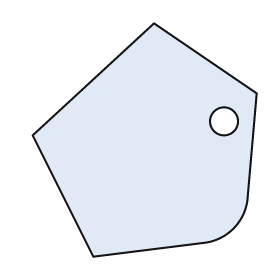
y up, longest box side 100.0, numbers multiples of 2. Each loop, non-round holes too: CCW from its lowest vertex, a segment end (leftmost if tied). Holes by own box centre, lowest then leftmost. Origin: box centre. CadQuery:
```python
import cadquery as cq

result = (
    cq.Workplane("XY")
    .moveTo(-22.0, -50.0)
    .lineTo(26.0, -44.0)
    .threePointArc((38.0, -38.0), (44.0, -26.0))
    .lineTo(48.0, 20.0)
    .lineTo(4.0, 50.0)
    .lineTo(-48.0, 2.0)
    .close()
    .moveTo(34.0, 8.0)
    .circle(6.0)
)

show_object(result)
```